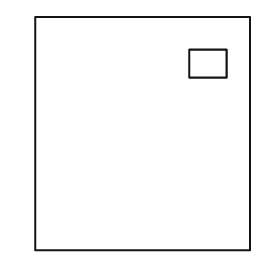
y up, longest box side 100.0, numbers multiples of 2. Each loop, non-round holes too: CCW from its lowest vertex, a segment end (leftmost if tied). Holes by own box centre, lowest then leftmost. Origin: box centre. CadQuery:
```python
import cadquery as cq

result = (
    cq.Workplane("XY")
    .moveTo(-46.0, -50.0)
    .lineTo(46.0, -50.0)
    .lineTo(46.0, 50.0)
    .lineTo(-46.0, 50.0)
    .close()
    .moveTo(20.0, 24.0)
    .lineTo(36.0, 24.0)
    .lineTo(36.0, 36.0)
    .lineTo(20.0, 36.0)
    .close()
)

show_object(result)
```